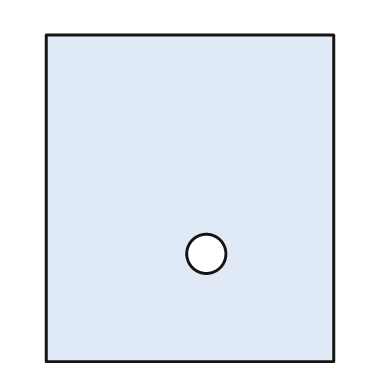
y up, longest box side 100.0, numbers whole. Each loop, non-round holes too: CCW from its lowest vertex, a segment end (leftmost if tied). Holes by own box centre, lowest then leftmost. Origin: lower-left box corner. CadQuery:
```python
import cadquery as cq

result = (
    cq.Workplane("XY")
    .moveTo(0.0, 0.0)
    .lineTo(88.0, 0.0)
    .lineTo(88.0, 100.0)
    .lineTo(0.0, 100.0)
    .close()
    .moveTo(49.0, 33.0)
    .circle(6.0)
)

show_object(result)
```